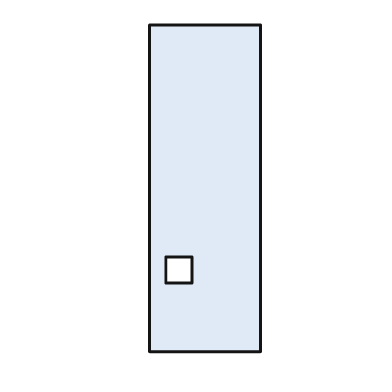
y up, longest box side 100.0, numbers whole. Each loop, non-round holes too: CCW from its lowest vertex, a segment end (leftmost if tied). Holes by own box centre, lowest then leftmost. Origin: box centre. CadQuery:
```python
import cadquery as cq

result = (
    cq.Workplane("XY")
    .moveTo(-17.0, -50.0)
    .lineTo(17.0, -50.0)
    .lineTo(17.0, 50.0)
    .lineTo(-17.0, 50.0)
    .close()
    .moveTo(-12.0, -29.0)
    .lineTo(-4.0, -29.0)
    .lineTo(-4.0, -21.0)
    .lineTo(-12.0, -21.0)
    .close()
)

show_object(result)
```